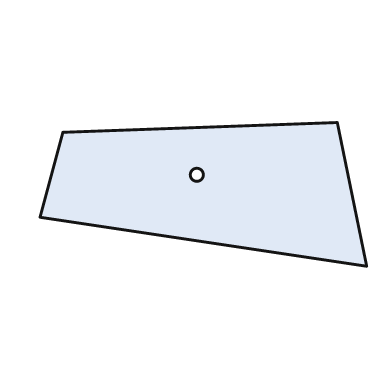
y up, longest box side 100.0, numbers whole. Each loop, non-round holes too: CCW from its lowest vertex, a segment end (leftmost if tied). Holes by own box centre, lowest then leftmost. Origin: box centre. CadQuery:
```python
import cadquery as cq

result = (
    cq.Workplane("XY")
    .moveTo(50.0, -22.0)
    .lineTo(41.0, 22.0)
    .lineTo(-43.0, 19.0)
    .lineTo(-50.0, -7.0)
    .close()
    .moveTo(-2.0, 6.0)
    .circle(2.0)
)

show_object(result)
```